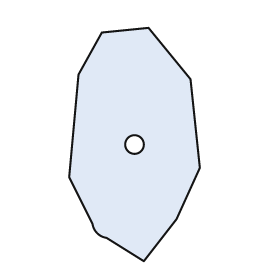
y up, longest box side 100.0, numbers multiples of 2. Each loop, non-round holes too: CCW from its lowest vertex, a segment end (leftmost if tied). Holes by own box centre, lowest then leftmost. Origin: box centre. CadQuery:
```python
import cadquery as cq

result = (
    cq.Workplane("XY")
    .moveTo(4.0, -50.0)
    .lineTo(18.0, -32.0)
    .lineTo(28.0, -10.0)
    .lineTo(24.0, 28.0)
    .lineTo(6.0, 50.0)
    .lineTo(-14.0, 48.0)
    .lineTo(-24.0, 30.0)
    .lineTo(-28.0, -14.0)
    .lineTo(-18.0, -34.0)
    .threePointArc((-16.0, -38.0), (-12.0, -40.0))
    .close()
    .moveTo(0.0, 0.0)
    .circle(4.0)
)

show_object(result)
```